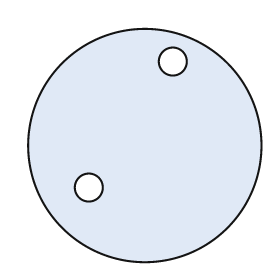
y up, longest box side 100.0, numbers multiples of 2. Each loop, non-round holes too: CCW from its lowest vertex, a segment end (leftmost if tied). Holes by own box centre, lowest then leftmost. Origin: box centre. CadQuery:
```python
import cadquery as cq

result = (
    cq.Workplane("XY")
    .moveTo(0.0, 0.0)
    .circle(50.0)
    .moveTo(-24.0, -18.0)
    .circle(6.0)
    .moveTo(12.0, 36.0)
    .circle(6.0)
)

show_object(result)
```